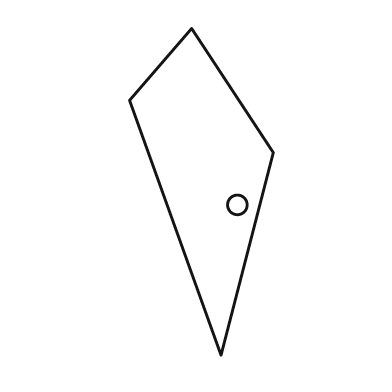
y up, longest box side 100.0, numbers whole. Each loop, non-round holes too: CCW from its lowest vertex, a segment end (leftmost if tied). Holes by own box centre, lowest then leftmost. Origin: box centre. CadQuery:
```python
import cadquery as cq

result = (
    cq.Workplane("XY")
    .moveTo(6.0, -50.0)
    .lineTo(22.0, 12.0)
    .lineTo(-3.0, 50.0)
    .lineTo(-22.0, 28.0)
    .close()
    .moveTo(11.0, -4.0)
    .circle(3.0)
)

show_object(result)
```